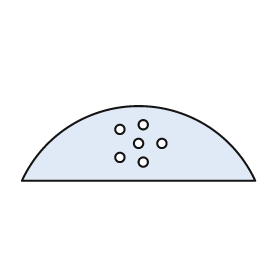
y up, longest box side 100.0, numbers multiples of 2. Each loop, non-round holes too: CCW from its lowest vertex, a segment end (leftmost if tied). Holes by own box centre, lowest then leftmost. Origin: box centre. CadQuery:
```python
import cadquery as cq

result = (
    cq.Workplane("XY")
    .moveTo(-50.0, -16.0)
    .lineTo(50.0, -16.0)
    .threePointArc((0.0, 16.0), (-50.0, -16.0))
    .close()
    .moveTo(2.0, -8.0)
    .circle(2.0)
    .moveTo(-8.0, -6.0)
    .circle(2.0)
    .moveTo(0.0, 0.0)
    .circle(2.0)
    .moveTo(10.0, 0.0)
    .circle(2.0)
    .moveTo(-8.0, 6.0)
    .circle(2.0)
    .moveTo(2.0, 8.0)
    .circle(2.0)
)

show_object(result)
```